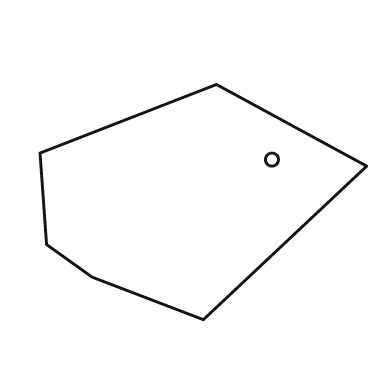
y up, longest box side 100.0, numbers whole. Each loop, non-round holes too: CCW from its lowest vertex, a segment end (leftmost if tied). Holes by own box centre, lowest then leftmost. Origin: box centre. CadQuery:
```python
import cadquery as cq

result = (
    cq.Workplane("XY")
    .moveTo(0.0, -36.0)
    .lineTo(50.0, 11.0)
    .lineTo(4.0, 36.0)
    .lineTo(-50.0, 15.0)
    .lineTo(-48.0, -13.0)
    .lineTo(-34.0, -23.0)
    .close()
    .moveTo(21.0, 13.0)
    .circle(2.0)
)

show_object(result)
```